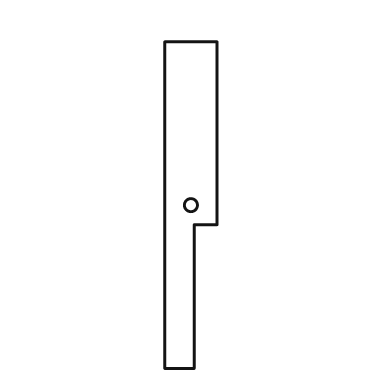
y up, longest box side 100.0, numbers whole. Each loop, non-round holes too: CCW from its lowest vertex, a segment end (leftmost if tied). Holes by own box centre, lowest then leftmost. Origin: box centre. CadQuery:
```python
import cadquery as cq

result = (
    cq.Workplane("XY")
    .moveTo(-8.0, -50.0)
    .lineTo(1.0, -50.0)
    .lineTo(1.0, -6.0)
    .lineTo(8.0, -6.0)
    .lineTo(8.0, 50.0)
    .lineTo(-8.0, 50.0)
    .close()
    .moveTo(0.0, 0.0)
    .circle(2.0)
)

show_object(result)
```